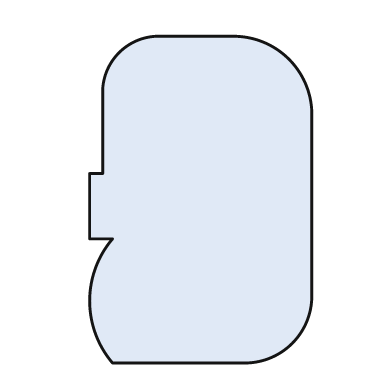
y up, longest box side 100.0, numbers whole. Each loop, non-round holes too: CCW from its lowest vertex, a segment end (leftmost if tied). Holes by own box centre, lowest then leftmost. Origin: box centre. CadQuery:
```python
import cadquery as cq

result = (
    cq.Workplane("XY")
    .moveTo(-27.0, -50.0)
    .lineTo(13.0, -50.0)
    .threePointArc((28.0, -44.0), (34.0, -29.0))
    .lineTo(34.0, 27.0)
    .threePointArc((27.0, 43.0), (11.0, 50.0))
    .lineTo(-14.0, 50.0)
    .threePointArc((-25.0, 45.0), (-30.0, 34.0))
    .lineTo(-30.0, 8.0)
    .lineTo(-34.0, 8.0)
    .lineTo(-34.0, -12.0)
    .lineTo(-27.0, -12.0)
    .threePointArc((-34.0, -31.0), (-27.0, -50.0))
    .close()
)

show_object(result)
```